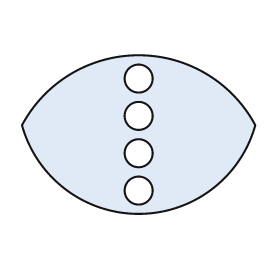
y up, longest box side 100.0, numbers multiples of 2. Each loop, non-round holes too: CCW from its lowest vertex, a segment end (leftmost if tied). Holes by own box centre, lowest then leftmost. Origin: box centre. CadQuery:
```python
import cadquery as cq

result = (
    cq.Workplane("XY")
    .moveTo(-50.0, 4.0)
    .threePointArc((0.0, -34.0), (50.0, 4.0))
    .threePointArc((0.0, 34.0), (-50.0, 4.0))
    .close()
    .moveTo(0.0, -24.0)
    .circle(6.0)
    .moveTo(0.0, -8.0)
    .circle(6.0)
    .moveTo(0.0, 8.0)
    .circle(6.0)
    .moveTo(0.0, 24.0)
    .circle(6.0)
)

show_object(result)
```